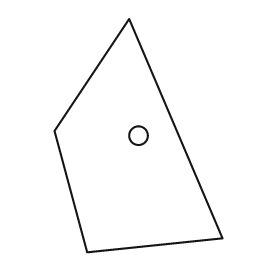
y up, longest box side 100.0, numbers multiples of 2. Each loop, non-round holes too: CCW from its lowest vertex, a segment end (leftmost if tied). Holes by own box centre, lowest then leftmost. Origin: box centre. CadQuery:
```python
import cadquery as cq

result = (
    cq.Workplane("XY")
    .moveTo(-22.0, -50.0)
    .lineTo(36.0, -44.0)
    .lineTo(-4.0, 50.0)
    .lineTo(-36.0, 2.0)
    .close()
    .moveTo(0.0, 0.0)
    .circle(4.0)
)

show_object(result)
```